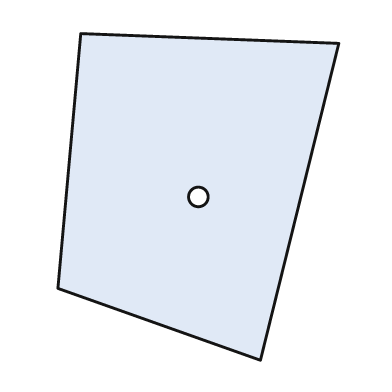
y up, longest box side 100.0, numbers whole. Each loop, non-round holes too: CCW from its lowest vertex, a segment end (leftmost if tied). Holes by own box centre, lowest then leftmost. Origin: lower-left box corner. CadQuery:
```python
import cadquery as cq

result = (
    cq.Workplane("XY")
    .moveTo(62.0, 0.0)
    .lineTo(86.0, 97.0)
    .lineTo(7.0, 100.0)
    .lineTo(0.0, 22.0)
    .close()
    .moveTo(43.0, 50.0)
    .circle(3.0)
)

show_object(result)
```